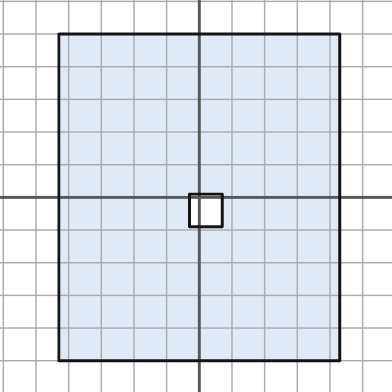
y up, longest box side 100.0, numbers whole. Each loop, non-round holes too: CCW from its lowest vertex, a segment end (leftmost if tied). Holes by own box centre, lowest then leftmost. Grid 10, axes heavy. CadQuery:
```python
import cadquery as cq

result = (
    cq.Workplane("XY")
    .moveTo(-43.0, -50.0)
    .lineTo(43.0, -50.0)
    .lineTo(43.0, 50.0)
    .lineTo(-43.0, 50.0)
    .close()
    .moveTo(-3.0, -9.0)
    .lineTo(7.0, -9.0)
    .lineTo(7.0, 1.0)
    .lineTo(-3.0, 1.0)
    .close()
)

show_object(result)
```